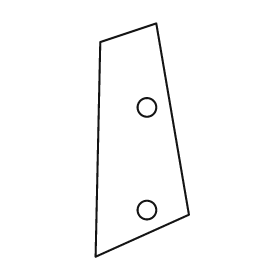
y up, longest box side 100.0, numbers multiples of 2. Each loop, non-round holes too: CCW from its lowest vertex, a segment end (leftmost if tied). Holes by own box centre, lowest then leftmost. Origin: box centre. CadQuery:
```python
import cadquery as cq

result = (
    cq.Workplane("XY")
    .moveTo(-20.0, -50.0)
    .lineTo(20.0, -32.0)
    .lineTo(6.0, 50.0)
    .lineTo(-18.0, 42.0)
    .close()
    .moveTo(2.0, -30.0)
    .circle(4.0)
    .moveTo(2.0, 14.0)
    .circle(4.0)
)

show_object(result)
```